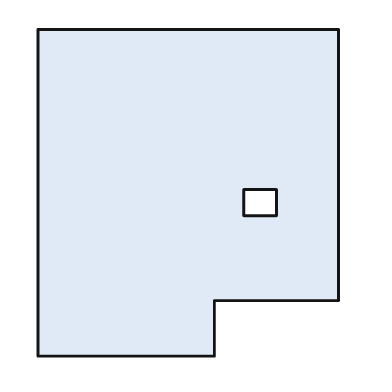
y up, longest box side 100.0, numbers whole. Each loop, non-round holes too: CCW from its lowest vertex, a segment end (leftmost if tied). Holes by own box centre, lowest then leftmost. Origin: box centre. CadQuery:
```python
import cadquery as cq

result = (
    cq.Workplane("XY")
    .moveTo(-46.0, -50.0)
    .lineTo(8.0, -50.0)
    .lineTo(8.0, -33.0)
    .lineTo(46.0, -33.0)
    .lineTo(46.0, 50.0)
    .lineTo(-46.0, 50.0)
    .close()
    .moveTo(17.0, -7.0)
    .lineTo(27.0, -7.0)
    .lineTo(27.0, 1.0)
    .lineTo(17.0, 1.0)
    .close()
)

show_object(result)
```